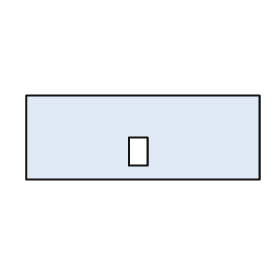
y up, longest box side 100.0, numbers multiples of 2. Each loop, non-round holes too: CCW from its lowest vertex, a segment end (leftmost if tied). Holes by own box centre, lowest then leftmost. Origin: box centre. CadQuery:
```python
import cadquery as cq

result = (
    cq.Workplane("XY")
    .moveTo(-50.0, -18.0)
    .lineTo(50.0, -18.0)
    .lineTo(50.0, 18.0)
    .lineTo(-50.0, 18.0)
    .close()
    .moveTo(-6.0, -12.0)
    .lineTo(2.0, -12.0)
    .lineTo(2.0, 0.0)
    .lineTo(-6.0, 0.0)
    .close()
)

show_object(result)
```